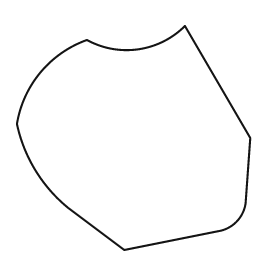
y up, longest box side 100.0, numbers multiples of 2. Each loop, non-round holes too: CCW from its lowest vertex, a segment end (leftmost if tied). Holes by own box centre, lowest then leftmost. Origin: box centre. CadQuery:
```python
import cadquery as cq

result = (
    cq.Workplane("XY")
    .moveTo(-4.0, -48.0)
    .lineTo(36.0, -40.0)
    .threePointArc((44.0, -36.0), (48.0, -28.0))
    .lineTo(50.0, 0.0)
    .lineTo(22.0, 48.0)
    .threePointArc((2.0, 38.0), (-20.0, 42.0))
    .threePointArc((-40.0, 28.0), (-50.0, 6.0))
    .threePointArc((-42.0, -14.0), (-28.0, -30.0))
    .close()
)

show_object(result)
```